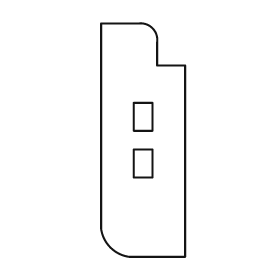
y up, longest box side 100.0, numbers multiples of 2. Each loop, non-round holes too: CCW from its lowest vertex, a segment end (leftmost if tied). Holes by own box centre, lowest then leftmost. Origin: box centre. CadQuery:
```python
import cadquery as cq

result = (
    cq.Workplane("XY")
    .moveTo(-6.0, -50.0)
    .lineTo(18.0, -50.0)
    .lineTo(18.0, 32.0)
    .lineTo(6.0, 32.0)
    .lineTo(6.0, 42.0)
    .threePointArc((4.0, 48.0), (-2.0, 50.0))
    .lineTo(-18.0, 50.0)
    .lineTo(-18.0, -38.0)
    .threePointArc((-14.0, -46.0), (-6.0, -50.0))
    .close()
    .moveTo(-4.0, -16.0)
    .lineTo(4.0, -16.0)
    .lineTo(4.0, -4.0)
    .lineTo(-4.0, -4.0)
    .close()
    .moveTo(-4.0, 4.0)
    .lineTo(4.0, 4.0)
    .lineTo(4.0, 16.0)
    .lineTo(-4.0, 16.0)
    .close()
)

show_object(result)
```